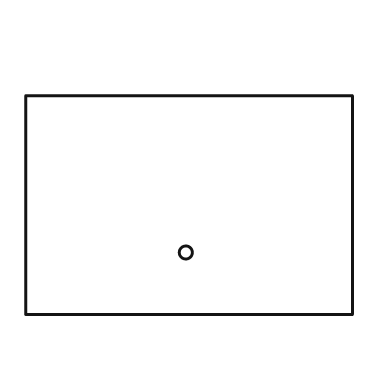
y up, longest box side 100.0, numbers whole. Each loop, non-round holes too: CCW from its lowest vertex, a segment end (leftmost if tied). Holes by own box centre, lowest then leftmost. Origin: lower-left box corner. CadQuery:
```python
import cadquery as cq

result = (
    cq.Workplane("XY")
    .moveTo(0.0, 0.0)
    .lineTo(100.0, 0.0)
    .lineTo(100.0, 67.0)
    .lineTo(0.0, 67.0)
    .close()
    .moveTo(49.0, 19.0)
    .circle(2.0)
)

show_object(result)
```